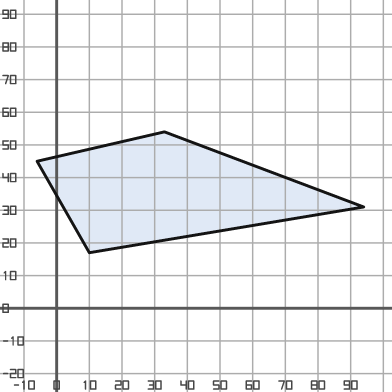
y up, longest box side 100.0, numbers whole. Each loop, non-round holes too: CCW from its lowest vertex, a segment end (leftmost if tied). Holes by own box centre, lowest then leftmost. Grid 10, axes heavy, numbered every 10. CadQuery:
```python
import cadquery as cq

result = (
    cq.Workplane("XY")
    .moveTo(10.0, 17.0)
    .lineTo(94.0, 31.0)
    .lineTo(33.0, 54.0)
    .lineTo(-6.0, 45.0)
    .close()
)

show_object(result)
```